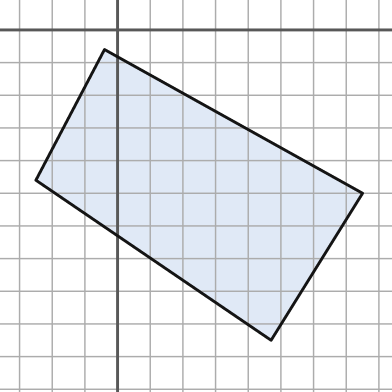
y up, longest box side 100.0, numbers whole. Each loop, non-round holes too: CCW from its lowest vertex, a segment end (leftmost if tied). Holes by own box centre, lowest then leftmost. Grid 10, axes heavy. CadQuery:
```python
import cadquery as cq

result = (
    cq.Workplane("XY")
    .moveTo(47.0, -95.0)
    .lineTo(75.0, -50.0)
    .lineTo(-4.0, -6.0)
    .lineTo(-25.0, -46.0)
    .close()
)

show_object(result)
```